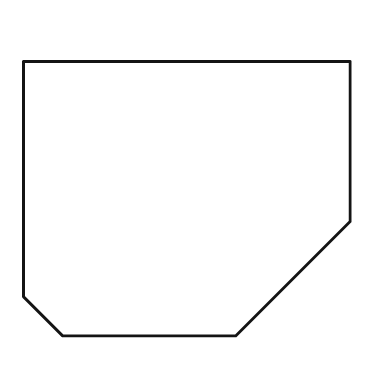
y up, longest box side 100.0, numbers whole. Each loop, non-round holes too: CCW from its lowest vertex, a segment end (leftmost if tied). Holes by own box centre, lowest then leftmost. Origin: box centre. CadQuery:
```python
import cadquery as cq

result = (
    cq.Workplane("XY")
    .moveTo(-38.0, -42.0)
    .lineTo(15.0, -42.0)
    .lineTo(50.0, -7.0)
    .lineTo(50.0, 42.0)
    .lineTo(-50.0, 42.0)
    .lineTo(-50.0, -30.0)
    .close()
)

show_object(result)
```